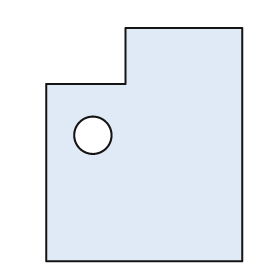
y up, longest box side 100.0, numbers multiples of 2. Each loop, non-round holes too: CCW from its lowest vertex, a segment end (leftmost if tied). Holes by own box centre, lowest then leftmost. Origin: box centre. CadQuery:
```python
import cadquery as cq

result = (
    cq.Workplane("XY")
    .moveTo(-42.0, -50.0)
    .lineTo(42.0, -50.0)
    .lineTo(42.0, 50.0)
    .lineTo(-8.0, 50.0)
    .lineTo(-8.0, 26.0)
    .lineTo(-42.0, 26.0)
    .close()
    .moveTo(-22.0, 4.0)
    .circle(8.0)
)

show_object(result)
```